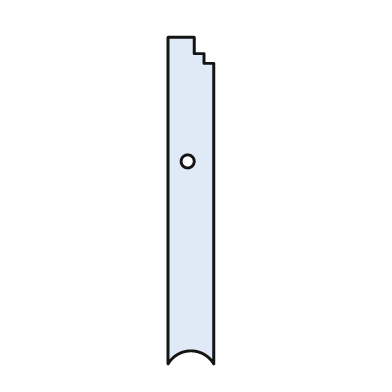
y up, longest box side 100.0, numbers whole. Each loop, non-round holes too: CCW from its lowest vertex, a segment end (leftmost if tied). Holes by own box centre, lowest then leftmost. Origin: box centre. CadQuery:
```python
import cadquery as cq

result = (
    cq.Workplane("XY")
    .moveTo(-7.0, -50.0)
    .threePointArc((0.0, -46.0), (7.0, -50.0))
    .lineTo(7.0, 42.0)
    .lineTo(4.0, 42.0)
    .lineTo(4.0, 45.0)
    .lineTo(1.0, 45.0)
    .lineTo(1.0, 50.0)
    .lineTo(-7.0, 50.0)
    .close()
    .moveTo(-1.0, 12.0)
    .circle(2.0)
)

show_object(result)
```